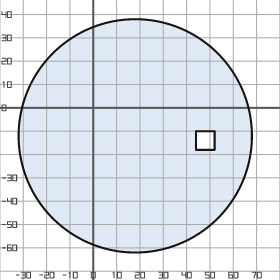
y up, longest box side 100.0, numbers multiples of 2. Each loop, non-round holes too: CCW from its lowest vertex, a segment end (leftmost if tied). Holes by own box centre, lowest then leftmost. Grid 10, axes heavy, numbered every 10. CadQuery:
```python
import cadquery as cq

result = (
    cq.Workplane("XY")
    .moveTo(18.0, -12.0)
    .circle(50.0)
    .moveTo(44.0, -18.0)
    .lineTo(52.0, -18.0)
    .lineTo(52.0, -10.0)
    .lineTo(44.0, -10.0)
    .close()
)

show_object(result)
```